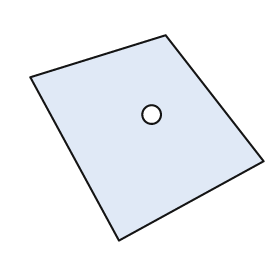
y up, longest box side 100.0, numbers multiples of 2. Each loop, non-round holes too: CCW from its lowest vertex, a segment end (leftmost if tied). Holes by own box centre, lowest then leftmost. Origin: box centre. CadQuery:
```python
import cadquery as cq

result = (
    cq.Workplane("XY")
    .moveTo(-12.0, -44.0)
    .lineTo(50.0, -10.0)
    .lineTo(8.0, 44.0)
    .lineTo(-50.0, 26.0)
    .close()
    .moveTo(2.0, 10.0)
    .circle(4.0)
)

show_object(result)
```